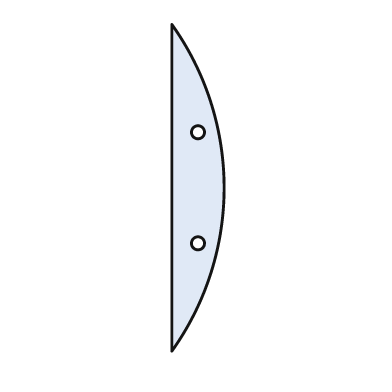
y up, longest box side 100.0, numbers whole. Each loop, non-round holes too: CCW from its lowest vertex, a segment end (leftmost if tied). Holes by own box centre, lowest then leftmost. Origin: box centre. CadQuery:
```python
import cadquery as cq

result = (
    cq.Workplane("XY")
    .moveTo(-8.0, -50.0)
    .threePointArc((8.0, 0.0), (-8.0, 50.0))
    .close()
    .moveTo(0.0, -17.0)
    .circle(2.0)
    .moveTo(0.0, 17.0)
    .circle(2.0)
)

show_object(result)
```